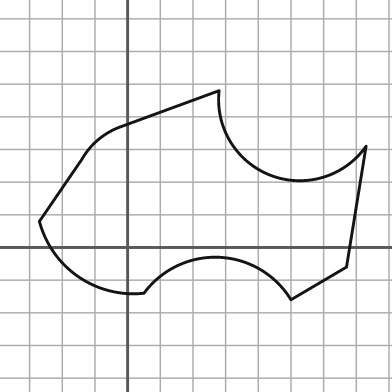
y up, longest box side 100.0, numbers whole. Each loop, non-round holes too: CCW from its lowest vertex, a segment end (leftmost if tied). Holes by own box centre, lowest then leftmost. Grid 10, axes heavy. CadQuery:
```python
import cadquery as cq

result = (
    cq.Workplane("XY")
    .moveTo(50.0, -16.0)
    .lineTo(67.0, -6.0)
    .lineTo(73.0, 31.0)
    .threePointArc((44.0, 22.0), (28.0, 48.0))
    .lineTo(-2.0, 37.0)
    .threePointArc((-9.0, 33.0), (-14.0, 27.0))
    .lineTo(-27.0, 8.0)
    .threePointArc((-15.0, -9.0), (5.0, -14.0))
    .threePointArc((28.0, -3.0), (50.0, -16.0))
    .close()
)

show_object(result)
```